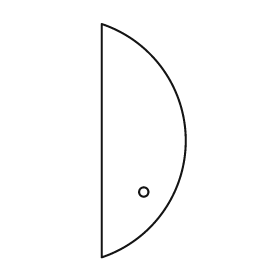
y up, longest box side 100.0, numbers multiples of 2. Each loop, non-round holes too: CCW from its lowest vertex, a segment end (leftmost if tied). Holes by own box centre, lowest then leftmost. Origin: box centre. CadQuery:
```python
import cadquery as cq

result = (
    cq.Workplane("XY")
    .moveTo(-18.0, -50.0)
    .threePointArc((18.0, 0.0), (-18.0, 50.0))
    .close()
    .moveTo(0.0, -22.0)
    .circle(2.0)
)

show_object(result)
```